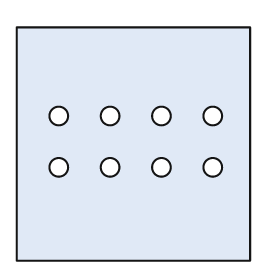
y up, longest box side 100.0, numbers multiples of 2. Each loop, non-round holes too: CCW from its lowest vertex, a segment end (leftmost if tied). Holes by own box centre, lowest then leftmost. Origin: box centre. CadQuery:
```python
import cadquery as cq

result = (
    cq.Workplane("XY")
    .moveTo(-50.0, -50.0)
    .lineTo(50.0, -50.0)
    .lineTo(50.0, 50.0)
    .lineTo(-50.0, 50.0)
    .close()
    .moveTo(-32.0, -10.0)
    .circle(4.0)
    .moveTo(-10.0, -10.0)
    .circle(4.0)
    .moveTo(12.0, -10.0)
    .circle(4.0)
    .moveTo(34.0, -10.0)
    .circle(4.0)
    .moveTo(-32.0, 12.0)
    .circle(4.0)
    .moveTo(-10.0, 12.0)
    .circle(4.0)
    .moveTo(12.0, 12.0)
    .circle(4.0)
    .moveTo(34.0, 12.0)
    .circle(4.0)
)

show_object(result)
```